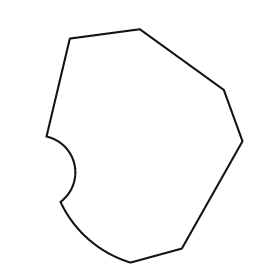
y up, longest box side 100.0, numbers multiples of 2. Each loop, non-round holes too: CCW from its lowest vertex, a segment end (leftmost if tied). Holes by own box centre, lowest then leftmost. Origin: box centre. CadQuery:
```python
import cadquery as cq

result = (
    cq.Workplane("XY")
    .moveTo(-6.0, -50.0)
    .lineTo(16.0, -44.0)
    .lineTo(42.0, 2.0)
    .lineTo(34.0, 24.0)
    .lineTo(-2.0, 50.0)
    .lineTo(-32.0, 46.0)
    .lineTo(-42.0, 4.0)
    .threePointArc((-30.0, -8.0), (-36.0, -24.0))
    .threePointArc((-24.0, -40.0), (-6.0, -50.0))
    .close()
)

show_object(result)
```